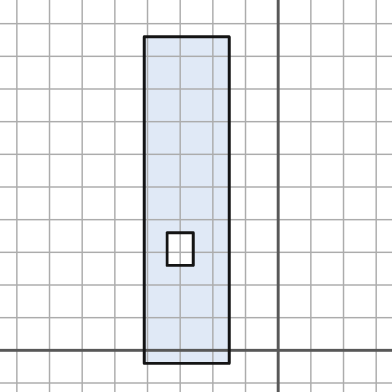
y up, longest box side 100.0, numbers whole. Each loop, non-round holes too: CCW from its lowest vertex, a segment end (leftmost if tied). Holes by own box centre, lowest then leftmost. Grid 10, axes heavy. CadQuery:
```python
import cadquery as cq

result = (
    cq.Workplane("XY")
    .moveTo(-41.0, -4.0)
    .lineTo(-15.0, -4.0)
    .lineTo(-15.0, 96.0)
    .lineTo(-41.0, 96.0)
    .close()
    .moveTo(-34.0, 26.0)
    .lineTo(-26.0, 26.0)
    .lineTo(-26.0, 36.0)
    .lineTo(-34.0, 36.0)
    .close()
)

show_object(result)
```